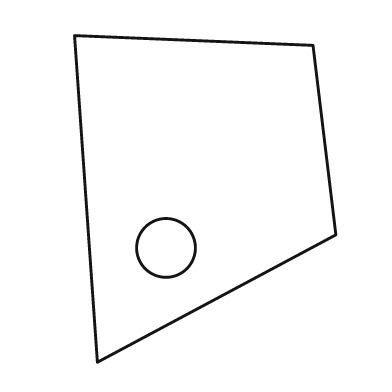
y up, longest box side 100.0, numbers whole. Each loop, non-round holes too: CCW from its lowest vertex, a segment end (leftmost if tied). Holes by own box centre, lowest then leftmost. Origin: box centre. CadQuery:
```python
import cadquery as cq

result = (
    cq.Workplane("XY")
    .moveTo(-33.0, -50.0)
    .lineTo(40.0, -11.0)
    .lineTo(33.0, 47.0)
    .lineTo(-40.0, 50.0)
    .close()
    .moveTo(-12.0, -15.0)
    .circle(9.0)
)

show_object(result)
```